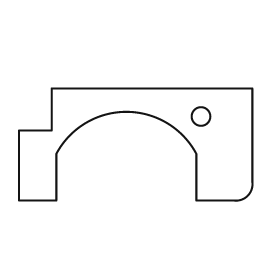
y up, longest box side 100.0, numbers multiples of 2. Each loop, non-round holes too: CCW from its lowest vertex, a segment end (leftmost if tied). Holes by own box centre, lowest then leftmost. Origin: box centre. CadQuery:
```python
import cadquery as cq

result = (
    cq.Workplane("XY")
    .moveTo(-50.0, -24.0)
    .lineTo(-34.0, -24.0)
    .lineTo(-34.0, -4.0)
    .threePointArc((-4.0, 14.0), (26.0, -4.0))
    .lineTo(26.0, -24.0)
    .lineTo(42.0, -24.0)
    .threePointArc((48.0, -22.0), (50.0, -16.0))
    .lineTo(50.0, 24.0)
    .lineTo(-36.0, 24.0)
    .lineTo(-36.0, 6.0)
    .lineTo(-50.0, 6.0)
    .close()
    .moveTo(28.0, 12.0)
    .circle(4.0)
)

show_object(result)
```